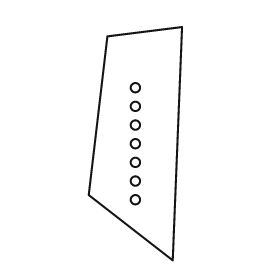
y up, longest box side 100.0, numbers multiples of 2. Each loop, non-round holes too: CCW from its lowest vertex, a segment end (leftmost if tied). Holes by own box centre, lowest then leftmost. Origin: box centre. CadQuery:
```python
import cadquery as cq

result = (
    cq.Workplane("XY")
    .moveTo(16.0, -50.0)
    .lineTo(20.0, 50.0)
    .lineTo(-12.0, 46.0)
    .lineTo(-20.0, -22.0)
    .close()
    .moveTo(0.0, -24.0)
    .circle(2.0)
    .moveTo(0.0, -16.0)
    .circle(2.0)
    .moveTo(0.0, -8.0)
    .circle(2.0)
    .moveTo(0.0, 0.0)
    .circle(2.0)
    .moveTo(0.0, 8.0)
    .circle(2.0)
    .moveTo(0.0, 16.0)
    .circle(2.0)
    .moveTo(0.0, 24.0)
    .circle(2.0)
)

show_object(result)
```